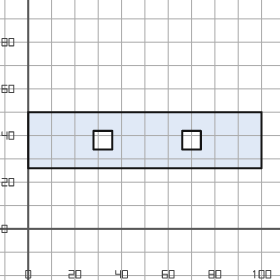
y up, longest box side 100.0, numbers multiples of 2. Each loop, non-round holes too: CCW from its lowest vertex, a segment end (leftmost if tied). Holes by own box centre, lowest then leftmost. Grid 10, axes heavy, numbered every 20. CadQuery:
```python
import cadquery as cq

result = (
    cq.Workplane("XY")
    .moveTo(0.0, 26.0)
    .lineTo(100.0, 26.0)
    .lineTo(100.0, 50.0)
    .lineTo(0.0, 50.0)
    .close()
    .moveTo(28.0, 34.0)
    .lineTo(36.0, 34.0)
    .lineTo(36.0, 42.0)
    .lineTo(28.0, 42.0)
    .close()
    .moveTo(66.0, 34.0)
    .lineTo(74.0, 34.0)
    .lineTo(74.0, 42.0)
    .lineTo(66.0, 42.0)
    .close()
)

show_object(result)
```